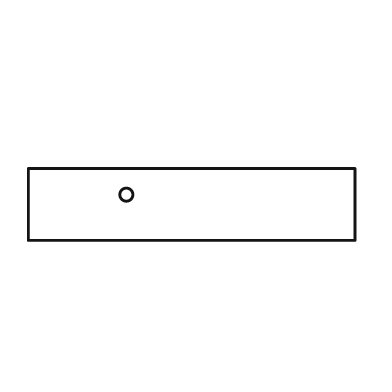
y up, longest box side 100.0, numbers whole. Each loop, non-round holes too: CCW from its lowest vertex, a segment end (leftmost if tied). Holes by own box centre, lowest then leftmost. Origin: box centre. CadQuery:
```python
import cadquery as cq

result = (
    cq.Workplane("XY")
    .moveTo(-50.0, -11.0)
    .lineTo(50.0, -11.0)
    .lineTo(50.0, 11.0)
    .lineTo(-50.0, 11.0)
    .close()
    .moveTo(-20.0, 3.0)
    .circle(2.0)
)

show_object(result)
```